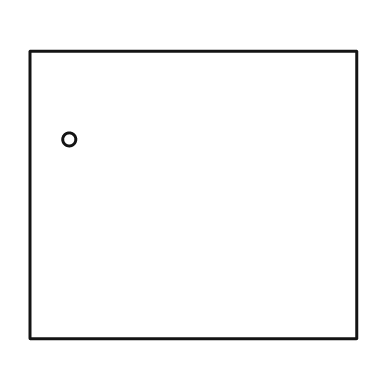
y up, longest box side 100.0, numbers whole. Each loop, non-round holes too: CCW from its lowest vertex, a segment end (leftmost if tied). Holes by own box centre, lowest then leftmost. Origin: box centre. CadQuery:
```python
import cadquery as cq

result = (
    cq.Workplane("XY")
    .moveTo(-50.0, -44.0)
    .lineTo(50.0, -44.0)
    .lineTo(50.0, 44.0)
    .lineTo(-50.0, 44.0)
    .close()
    .moveTo(-38.0, 17.0)
    .circle(2.0)
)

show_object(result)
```